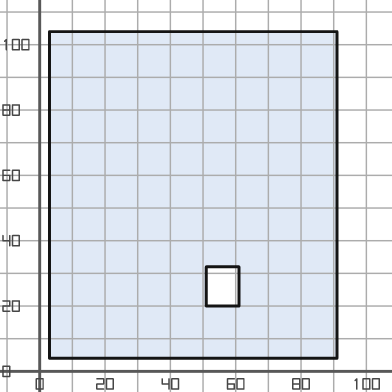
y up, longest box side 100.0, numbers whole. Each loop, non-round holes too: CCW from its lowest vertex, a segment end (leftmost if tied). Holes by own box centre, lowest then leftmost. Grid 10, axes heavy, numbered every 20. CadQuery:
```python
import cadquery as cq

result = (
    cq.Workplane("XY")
    .moveTo(3.0, 4.0)
    .lineTo(91.0, 4.0)
    .lineTo(91.0, 104.0)
    .lineTo(3.0, 104.0)
    .close()
    .moveTo(51.0, 20.0)
    .lineTo(61.0, 20.0)
    .lineTo(61.0, 32.0)
    .lineTo(51.0, 32.0)
    .close()
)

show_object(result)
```